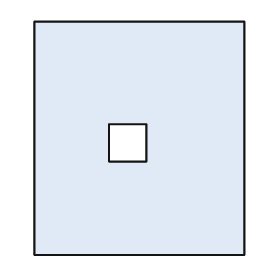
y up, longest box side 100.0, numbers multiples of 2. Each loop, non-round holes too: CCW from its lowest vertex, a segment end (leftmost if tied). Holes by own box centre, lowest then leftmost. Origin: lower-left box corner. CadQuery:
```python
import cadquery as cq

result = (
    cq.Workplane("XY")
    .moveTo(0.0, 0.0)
    .lineTo(90.0, 0.0)
    .lineTo(90.0, 100.0)
    .lineTo(0.0, 100.0)
    .close()
    .moveTo(32.0, 40.0)
    .lineTo(48.0, 40.0)
    .lineTo(48.0, 56.0)
    .lineTo(32.0, 56.0)
    .close()
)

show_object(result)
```